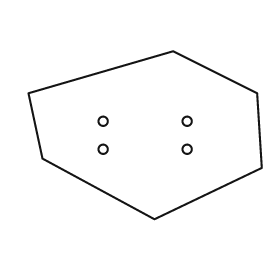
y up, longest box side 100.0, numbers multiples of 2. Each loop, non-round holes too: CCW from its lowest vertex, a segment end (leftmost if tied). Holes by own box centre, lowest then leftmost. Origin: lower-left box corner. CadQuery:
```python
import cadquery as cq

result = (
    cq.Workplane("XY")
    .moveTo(54.0, 0.0)
    .lineTo(100.0, 22.0)
    .lineTo(98.0, 54.0)
    .lineTo(62.0, 72.0)
    .lineTo(0.0, 54.0)
    .lineTo(6.0, 26.0)
    .close()
    .moveTo(32.0, 30.0)
    .circle(2.0)
    .moveTo(68.0, 30.0)
    .circle(2.0)
    .moveTo(32.0, 42.0)
    .circle(2.0)
    .moveTo(68.0, 42.0)
    .circle(2.0)
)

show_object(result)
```